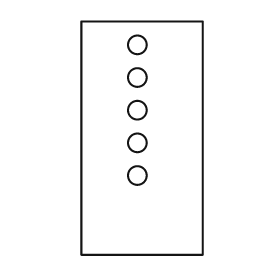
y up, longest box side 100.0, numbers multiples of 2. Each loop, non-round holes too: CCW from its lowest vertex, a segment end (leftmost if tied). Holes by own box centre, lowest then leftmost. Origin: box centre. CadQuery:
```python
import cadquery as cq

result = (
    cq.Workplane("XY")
    .moveTo(-26.0, -50.0)
    .lineTo(26.0, -50.0)
    .lineTo(26.0, 50.0)
    .lineTo(-26.0, 50.0)
    .close()
    .moveTo(-2.0, -16.0)
    .circle(4.0)
    .moveTo(-2.0, -2.0)
    .circle(4.0)
    .moveTo(-2.0, 12.0)
    .circle(4.0)
    .moveTo(-2.0, 26.0)
    .circle(4.0)
    .moveTo(-2.0, 40.0)
    .circle(4.0)
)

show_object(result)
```